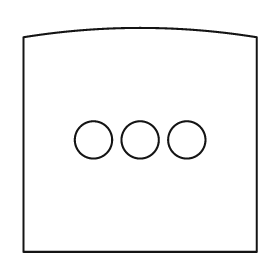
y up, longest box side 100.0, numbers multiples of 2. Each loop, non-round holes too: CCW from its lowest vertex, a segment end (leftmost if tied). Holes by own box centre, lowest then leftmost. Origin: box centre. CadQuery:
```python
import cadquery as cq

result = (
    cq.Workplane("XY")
    .moveTo(-50.0, -48.0)
    .lineTo(50.0, -48.0)
    .lineTo(50.0, 44.0)
    .threePointArc((0.0, 48.0), (-50.0, 44.0))
    .close()
    .moveTo(-20.0, 0.0)
    .circle(8.0)
    .moveTo(0.0, 0.0)
    .circle(8.0)
    .moveTo(20.0, 0.0)
    .circle(8.0)
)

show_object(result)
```